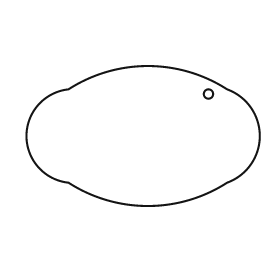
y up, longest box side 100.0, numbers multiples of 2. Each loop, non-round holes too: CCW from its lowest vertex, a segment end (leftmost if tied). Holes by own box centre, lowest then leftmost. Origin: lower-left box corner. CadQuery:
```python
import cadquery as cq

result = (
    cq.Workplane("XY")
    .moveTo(18.0, 10.0)
    .threePointArc((52.0, 0.0), (86.0, 10.0))
    .threePointArc((100.0, 30.0), (86.0, 50.0))
    .threePointArc((52.0, 60.0), (18.0, 50.0))
    .threePointArc((0.0, 30.0), (18.0, 10.0))
    .close()
    .moveTo(78.0, 48.0)
    .circle(2.0)
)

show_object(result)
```